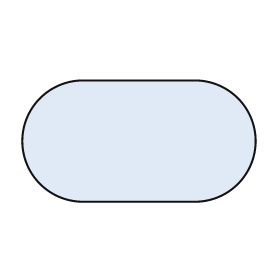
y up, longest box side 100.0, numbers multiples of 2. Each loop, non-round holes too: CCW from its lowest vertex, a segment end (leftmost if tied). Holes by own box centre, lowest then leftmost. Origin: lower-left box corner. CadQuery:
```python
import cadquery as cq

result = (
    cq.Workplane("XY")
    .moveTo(26.0, 0.0)
    .lineTo(74.0, 0.0)
    .threePointArc((100.0, 26.0), (74.0, 52.0))
    .lineTo(26.0, 52.0)
    .threePointArc((0.0, 26.0), (26.0, 0.0))
    .close()
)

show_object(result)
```